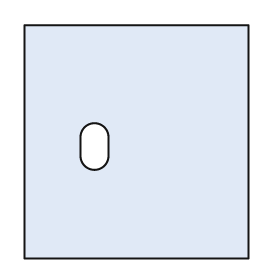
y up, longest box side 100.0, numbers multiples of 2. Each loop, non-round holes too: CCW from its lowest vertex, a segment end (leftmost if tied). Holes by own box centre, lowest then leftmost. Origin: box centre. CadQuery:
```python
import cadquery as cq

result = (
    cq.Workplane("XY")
    .moveTo(-48.0, -50.0)
    .lineTo(48.0, -50.0)
    .lineTo(48.0, 50.0)
    .lineTo(-48.0, 50.0)
    .close()
    .moveTo(-24.0, -6.0)
    .threePointArc((-18.0, -12.0), (-12.0, -6.0))
    .lineTo(-12.0, 2.0)
    .threePointArc((-18.0, 8.0), (-24.0, 2.0))
    .close()
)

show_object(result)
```